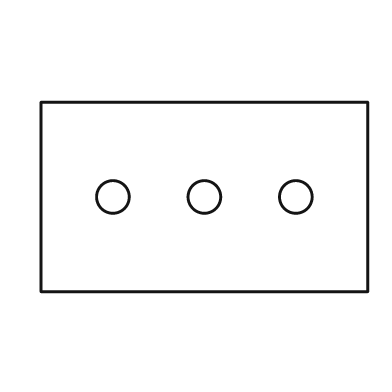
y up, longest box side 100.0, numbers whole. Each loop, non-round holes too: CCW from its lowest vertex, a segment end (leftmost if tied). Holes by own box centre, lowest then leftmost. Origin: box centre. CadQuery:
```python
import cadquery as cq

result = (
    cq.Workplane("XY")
    .moveTo(-50.0, -29.0)
    .lineTo(50.0, -29.0)
    .lineTo(50.0, 29.0)
    .lineTo(-50.0, 29.0)
    .close()
    .moveTo(-28.0, 0.0)
    .circle(5.0)
    .moveTo(0.0, 0.0)
    .circle(5.0)
    .moveTo(28.0, 0.0)
    .circle(5.0)
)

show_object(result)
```